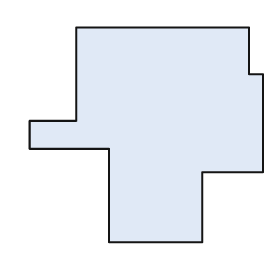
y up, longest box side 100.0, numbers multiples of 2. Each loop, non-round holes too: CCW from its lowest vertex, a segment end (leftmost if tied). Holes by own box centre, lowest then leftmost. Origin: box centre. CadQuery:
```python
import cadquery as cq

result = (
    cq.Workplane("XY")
    .moveTo(-16.0, -46.0)
    .lineTo(24.0, -46.0)
    .lineTo(24.0, -16.0)
    .lineTo(50.0, -16.0)
    .lineTo(50.0, 26.0)
    .lineTo(44.0, 26.0)
    .lineTo(44.0, 46.0)
    .lineTo(-30.0, 46.0)
    .lineTo(-30.0, 6.0)
    .lineTo(-50.0, 6.0)
    .lineTo(-50.0, -6.0)
    .lineTo(-16.0, -6.0)
    .close()
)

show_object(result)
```